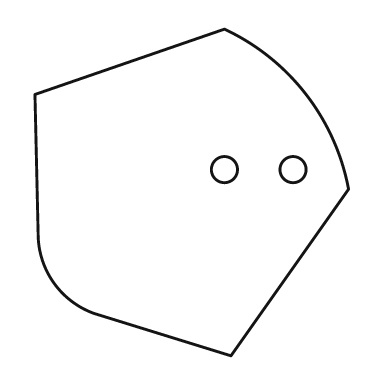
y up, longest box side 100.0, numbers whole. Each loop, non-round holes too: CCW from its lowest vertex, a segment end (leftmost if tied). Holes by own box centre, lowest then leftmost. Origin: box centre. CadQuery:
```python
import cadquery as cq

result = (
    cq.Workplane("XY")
    .moveTo(12.0, -50.0)
    .lineTo(48.0, 1.0)
    .threePointArc((35.0, 30.0), (10.0, 50.0))
    .lineTo(-48.0, 30.0)
    .lineTo(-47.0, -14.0)
    .threePointArc((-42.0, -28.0), (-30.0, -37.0))
    .close()
    .moveTo(10.0, 7.0)
    .circle(4.0)
    .moveTo(31.0, 7.0)
    .circle(4.0)
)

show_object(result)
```